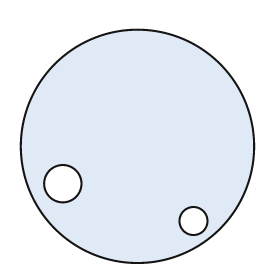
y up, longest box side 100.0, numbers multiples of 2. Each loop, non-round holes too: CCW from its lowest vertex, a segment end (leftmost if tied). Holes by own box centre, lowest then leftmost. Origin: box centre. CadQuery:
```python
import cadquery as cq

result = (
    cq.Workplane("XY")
    .moveTo(0.0, 0.0)
    .circle(50.0)
    .moveTo(24.0, -32.0)
    .circle(6.0)
    .moveTo(-32.0, -16.0)
    .circle(8.0)
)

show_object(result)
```